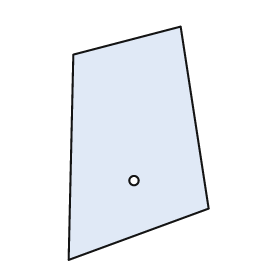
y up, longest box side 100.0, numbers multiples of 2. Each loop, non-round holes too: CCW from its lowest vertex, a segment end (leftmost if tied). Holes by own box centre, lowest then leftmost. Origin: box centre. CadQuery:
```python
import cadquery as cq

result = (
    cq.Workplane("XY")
    .moveTo(-30.0, -50.0)
    .lineTo(30.0, -28.0)
    .lineTo(18.0, 50.0)
    .lineTo(-28.0, 38.0)
    .close()
    .moveTo(-2.0, -16.0)
    .circle(2.0)
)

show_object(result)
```